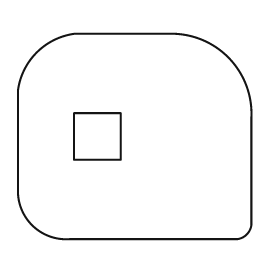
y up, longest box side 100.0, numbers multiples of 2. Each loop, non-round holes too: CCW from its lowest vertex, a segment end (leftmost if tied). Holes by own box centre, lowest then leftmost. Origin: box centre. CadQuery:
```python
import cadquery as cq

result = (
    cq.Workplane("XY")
    .moveTo(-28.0, -44.0)
    .lineTo(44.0, -44.0)
    .threePointArc((48.0, -42.0), (50.0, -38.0))
    .lineTo(50.0, 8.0)
    .threePointArc((40.0, 34.0), (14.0, 44.0))
    .lineTo(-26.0, 44.0)
    .threePointArc((-42.0, 36.0), (-50.0, 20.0))
    .lineTo(-50.0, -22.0)
    .threePointArc((-44.0, -38.0), (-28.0, -44.0))
    .close()
    .moveTo(-26.0, -10.0)
    .lineTo(-6.0, -10.0)
    .lineTo(-6.0, 10.0)
    .lineTo(-26.0, 10.0)
    .close()
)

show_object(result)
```